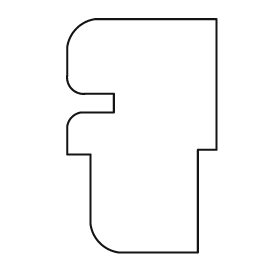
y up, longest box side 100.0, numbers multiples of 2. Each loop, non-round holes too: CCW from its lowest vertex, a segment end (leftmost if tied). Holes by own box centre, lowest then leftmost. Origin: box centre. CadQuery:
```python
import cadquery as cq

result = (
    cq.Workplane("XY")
    .moveTo(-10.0, -50.0)
    .lineTo(24.0, -50.0)
    .lineTo(24.0, -6.0)
    .lineTo(32.0, -6.0)
    .lineTo(32.0, 50.0)
    .lineTo(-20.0, 50.0)
    .threePointArc((-28.0, 46.0), (-32.0, 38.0))
    .lineTo(-32.0, 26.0)
    .threePointArc((-30.0, 20.0), (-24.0, 18.0))
    .lineTo(-12.0, 18.0)
    .lineTo(-12.0, 10.0)
    .lineTo(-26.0, 10.0)
    .threePointArc((-30.0, 8.0), (-32.0, 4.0))
    .lineTo(-32.0, -8.0)
    .lineTo(-22.0, -8.0)
    .lineTo(-22.0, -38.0)
    .threePointArc((-18.0, -46.0), (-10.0, -50.0))
    .close()
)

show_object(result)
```